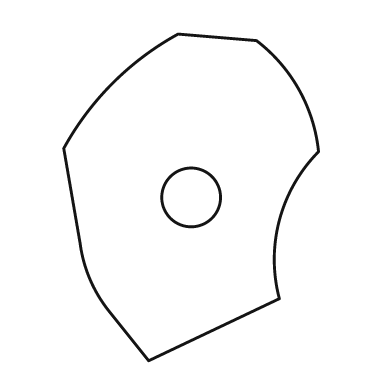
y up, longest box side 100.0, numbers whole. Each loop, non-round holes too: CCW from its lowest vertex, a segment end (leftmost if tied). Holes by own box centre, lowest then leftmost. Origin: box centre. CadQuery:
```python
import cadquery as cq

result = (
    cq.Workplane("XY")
    .moveTo(-13.0, -50.0)
    .lineTo(27.0, -31.0)
    .threePointArc((27.0, -7.0), (39.0, 14.0))
    .threePointArc((33.0, 33.0), (20.0, 48.0))
    .lineTo(-4.0, 50.0)
    .threePointArc((-24.0, 35.0), (-39.0, 15.0))
    .lineTo(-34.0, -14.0)
    .threePointArc((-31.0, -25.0), (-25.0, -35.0))
    .close()
    .moveTo(0.0, 0.0)
    .circle(9.0)
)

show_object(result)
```